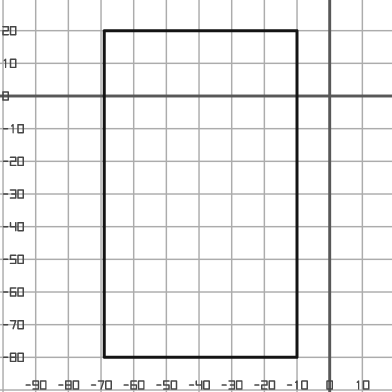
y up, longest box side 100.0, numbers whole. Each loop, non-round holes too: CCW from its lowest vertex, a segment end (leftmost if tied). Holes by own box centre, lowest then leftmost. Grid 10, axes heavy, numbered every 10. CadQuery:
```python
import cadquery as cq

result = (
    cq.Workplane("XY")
    .moveTo(-69.0, -80.0)
    .lineTo(-10.0, -80.0)
    .lineTo(-10.0, 20.0)
    .lineTo(-69.0, 20.0)
    .close()
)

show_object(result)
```